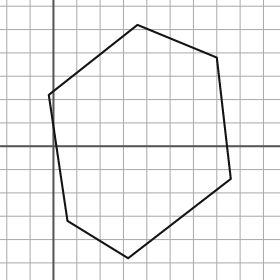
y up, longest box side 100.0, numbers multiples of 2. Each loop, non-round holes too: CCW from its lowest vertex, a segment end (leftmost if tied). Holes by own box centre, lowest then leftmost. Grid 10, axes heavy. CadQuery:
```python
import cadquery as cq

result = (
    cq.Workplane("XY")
    .moveTo(32.0, -48.0)
    .lineTo(76.0, -14.0)
    .lineTo(70.0, 38.0)
    .lineTo(36.0, 52.0)
    .lineTo(-2.0, 22.0)
    .lineTo(6.0, -32.0)
    .close()
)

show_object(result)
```